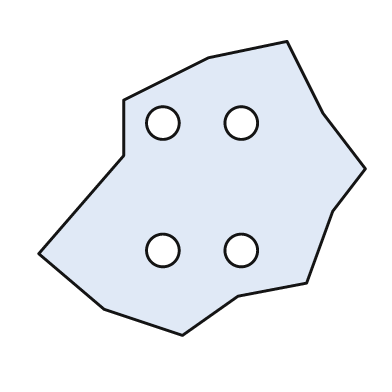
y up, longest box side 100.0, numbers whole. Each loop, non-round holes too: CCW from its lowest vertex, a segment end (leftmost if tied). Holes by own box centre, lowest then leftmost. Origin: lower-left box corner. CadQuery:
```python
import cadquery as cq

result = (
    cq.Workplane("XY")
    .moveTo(44.0, 0.0)
    .lineTo(61.0, 12.0)
    .lineTo(82.0, 16.0)
    .lineTo(90.0, 38.0)
    .lineTo(100.0, 51.0)
    .lineTo(87.0, 68.0)
    .lineTo(76.0, 90.0)
    .lineTo(52.0, 85.0)
    .lineTo(26.0, 72.0)
    .lineTo(26.0, 55.0)
    .lineTo(0.0, 25.0)
    .lineTo(20.0, 8.0)
    .close()
    .moveTo(38.0, 26.0)
    .circle(5.0)
    .moveTo(62.0, 26.0)
    .circle(5.0)
    .moveTo(38.0, 65.0)
    .circle(5.0)
    .moveTo(62.0, 65.0)
    .circle(5.0)
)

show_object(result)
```